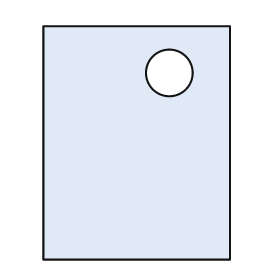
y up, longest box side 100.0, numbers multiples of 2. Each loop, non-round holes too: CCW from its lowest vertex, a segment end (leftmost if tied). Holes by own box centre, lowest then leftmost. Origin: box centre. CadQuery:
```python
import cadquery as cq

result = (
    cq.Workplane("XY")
    .moveTo(-40.0, -50.0)
    .lineTo(40.0, -50.0)
    .lineTo(40.0, 50.0)
    .lineTo(-40.0, 50.0)
    .close()
    .moveTo(14.0, 30.0)
    .circle(10.0)
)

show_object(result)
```